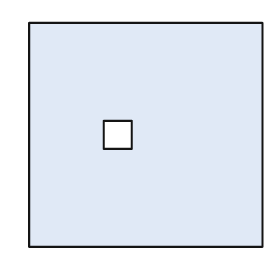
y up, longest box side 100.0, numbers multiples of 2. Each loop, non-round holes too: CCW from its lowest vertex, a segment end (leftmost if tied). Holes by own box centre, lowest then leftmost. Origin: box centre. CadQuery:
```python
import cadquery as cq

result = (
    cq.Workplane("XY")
    .moveTo(-50.0, -48.0)
    .lineTo(50.0, -48.0)
    .lineTo(50.0, 48.0)
    .lineTo(-50.0, 48.0)
    .close()
    .moveTo(-18.0, -6.0)
    .lineTo(-6.0, -6.0)
    .lineTo(-6.0, 6.0)
    .lineTo(-18.0, 6.0)
    .close()
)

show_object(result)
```